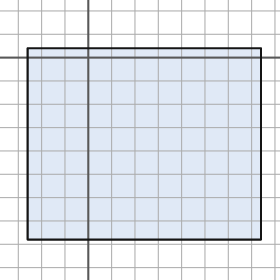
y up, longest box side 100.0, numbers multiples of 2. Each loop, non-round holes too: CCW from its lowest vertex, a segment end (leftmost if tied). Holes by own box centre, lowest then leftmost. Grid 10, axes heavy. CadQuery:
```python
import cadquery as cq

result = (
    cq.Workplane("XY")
    .moveTo(-26.0, -78.0)
    .lineTo(74.0, -78.0)
    .lineTo(74.0, 4.0)
    .lineTo(-26.0, 4.0)
    .close()
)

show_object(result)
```